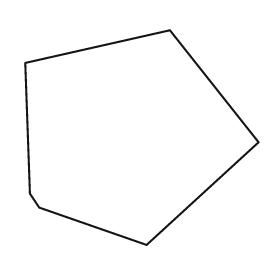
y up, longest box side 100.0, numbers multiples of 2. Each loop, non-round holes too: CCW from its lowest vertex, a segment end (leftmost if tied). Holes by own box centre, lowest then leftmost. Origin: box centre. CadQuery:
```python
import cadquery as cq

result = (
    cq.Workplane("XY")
    .moveTo(2.0, -46.0)
    .lineTo(50.0, -2.0)
    .lineTo(12.0, 46.0)
    .lineTo(-50.0, 32.0)
    .lineTo(-48.0, -24.0)
    .lineTo(-44.0, -30.0)
    .close()
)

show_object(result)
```